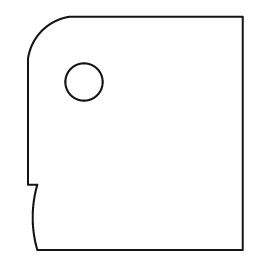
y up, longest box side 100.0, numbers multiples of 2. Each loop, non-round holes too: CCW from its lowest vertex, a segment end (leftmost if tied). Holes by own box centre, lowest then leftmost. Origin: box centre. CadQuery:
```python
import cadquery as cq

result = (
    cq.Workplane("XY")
    .moveTo(-42.0, -50.0)
    .lineTo(46.0, -50.0)
    .lineTo(46.0, 50.0)
    .lineTo(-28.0, 50.0)
    .threePointArc((-40.0, 44.0), (-46.0, 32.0))
    .lineTo(-46.0, -22.0)
    .lineTo(-42.0, -22.0)
    .threePointArc((-44.0, -36.0), (-42.0, -50.0))
    .close()
    .moveTo(-22.0, 22.0)
    .circle(8.0)
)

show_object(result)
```